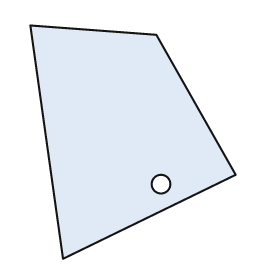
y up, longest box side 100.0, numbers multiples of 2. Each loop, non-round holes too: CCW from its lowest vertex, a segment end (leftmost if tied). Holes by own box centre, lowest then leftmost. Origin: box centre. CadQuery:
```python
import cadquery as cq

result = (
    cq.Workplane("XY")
    .moveTo(-30.0, -50.0)
    .lineTo(44.0, -14.0)
    .lineTo(10.0, 46.0)
    .lineTo(-44.0, 50.0)
    .close()
    .moveTo(12.0, -18.0)
    .circle(4.0)
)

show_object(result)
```